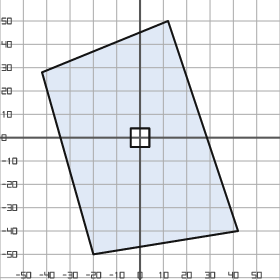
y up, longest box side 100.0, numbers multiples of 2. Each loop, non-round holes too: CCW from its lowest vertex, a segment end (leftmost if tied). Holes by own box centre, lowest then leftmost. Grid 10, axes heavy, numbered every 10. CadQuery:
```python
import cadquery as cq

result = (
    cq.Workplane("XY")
    .moveTo(-20.0, -50.0)
    .lineTo(42.0, -40.0)
    .lineTo(12.0, 50.0)
    .lineTo(-42.0, 28.0)
    .close()
    .moveTo(-4.0, -4.0)
    .lineTo(4.0, -4.0)
    .lineTo(4.0, 4.0)
    .lineTo(-4.0, 4.0)
    .close()
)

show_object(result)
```